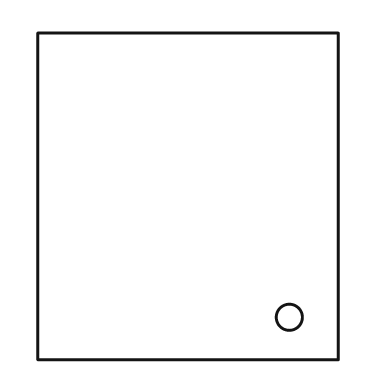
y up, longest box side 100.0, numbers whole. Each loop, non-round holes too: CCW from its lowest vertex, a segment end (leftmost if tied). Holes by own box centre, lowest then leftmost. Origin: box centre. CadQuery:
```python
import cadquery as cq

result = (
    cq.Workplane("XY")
    .moveTo(-46.0, -50.0)
    .lineTo(46.0, -50.0)
    .lineTo(46.0, 50.0)
    .lineTo(-46.0, 50.0)
    .close()
    .moveTo(31.0, -37.0)
    .circle(4.0)
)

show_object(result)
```